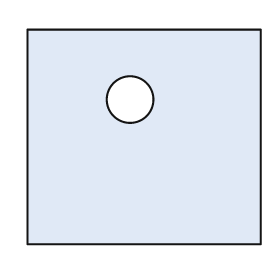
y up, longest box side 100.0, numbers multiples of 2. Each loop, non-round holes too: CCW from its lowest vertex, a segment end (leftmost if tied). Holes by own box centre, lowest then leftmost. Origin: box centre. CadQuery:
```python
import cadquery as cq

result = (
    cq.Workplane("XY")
    .moveTo(-50.0, -46.0)
    .lineTo(50.0, -46.0)
    .lineTo(50.0, 46.0)
    .lineTo(-50.0, 46.0)
    .close()
    .moveTo(-6.0, 16.0)
    .circle(10.0)
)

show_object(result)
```